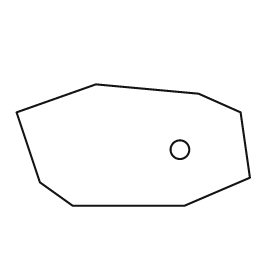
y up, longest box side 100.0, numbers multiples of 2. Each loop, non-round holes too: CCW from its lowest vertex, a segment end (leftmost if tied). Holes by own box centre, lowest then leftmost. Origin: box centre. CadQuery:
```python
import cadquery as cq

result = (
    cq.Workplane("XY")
    .moveTo(-26.0, -26.0)
    .lineTo(22.0, -26.0)
    .lineTo(50.0, -14.0)
    .lineTo(46.0, 14.0)
    .lineTo(28.0, 22.0)
    .lineTo(-16.0, 26.0)
    .lineTo(-50.0, 14.0)
    .lineTo(-40.0, -16.0)
    .close()
    .moveTo(20.0, -2.0)
    .circle(4.0)
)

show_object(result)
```